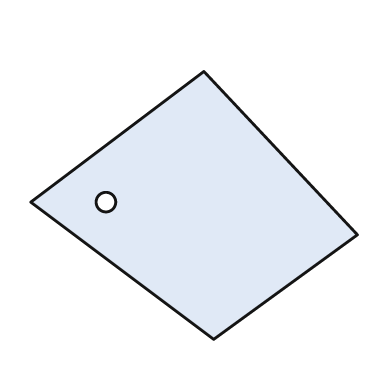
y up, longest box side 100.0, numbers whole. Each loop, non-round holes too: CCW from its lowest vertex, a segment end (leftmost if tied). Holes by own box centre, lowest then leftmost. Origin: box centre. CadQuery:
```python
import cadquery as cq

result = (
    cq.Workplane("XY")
    .moveTo(6.0, -41.0)
    .lineTo(50.0, -9.0)
    .lineTo(3.0, 41.0)
    .lineTo(-50.0, 1.0)
    .close()
    .moveTo(-27.0, 1.0)
    .circle(3.0)
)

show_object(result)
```